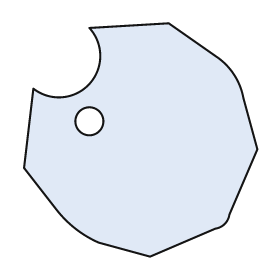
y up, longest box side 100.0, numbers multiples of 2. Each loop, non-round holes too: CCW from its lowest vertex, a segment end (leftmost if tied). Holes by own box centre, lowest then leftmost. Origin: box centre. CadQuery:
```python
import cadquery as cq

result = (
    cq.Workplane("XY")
    .moveTo(4.0, -50.0)
    .lineTo(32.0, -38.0)
    .threePointArc((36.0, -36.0), (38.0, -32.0))
    .lineTo(50.0, -4.0)
    .lineTo(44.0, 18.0)
    .threePointArc((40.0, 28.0), (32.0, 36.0))
    .lineTo(12.0, 50.0)
    .lineTo(-22.0, 48.0)
    .threePointArc((-22.0, 24.0), (-46.0, 22.0))
    .lineTo(-50.0, -12.0)
    .lineTo(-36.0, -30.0)
    .threePointArc((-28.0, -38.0), (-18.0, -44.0))
    .close()
    .moveTo(-22.0, 8.0)
    .circle(6.0)
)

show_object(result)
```